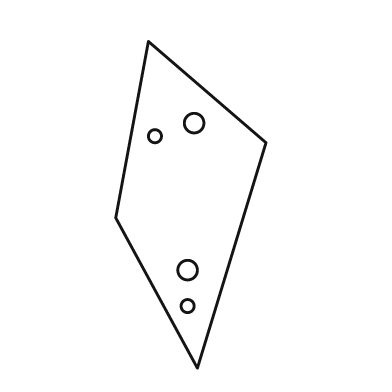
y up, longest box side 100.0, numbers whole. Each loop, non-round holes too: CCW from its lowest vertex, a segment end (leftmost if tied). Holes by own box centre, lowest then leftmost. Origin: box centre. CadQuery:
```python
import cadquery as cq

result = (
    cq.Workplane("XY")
    .moveTo(2.0, -50.0)
    .lineTo(23.0, 19.0)
    .lineTo(-13.0, 50.0)
    .lineTo(-23.0, -4.0)
    .close()
    .moveTo(-1.0, -31.0)
    .circle(2.0)
    .moveTo(-1.0, -20.0)
    .circle(3.0)
    .moveTo(-11.0, 21.0)
    .circle(2.0)
    .moveTo(1.0, 25.0)
    .circle(3.0)
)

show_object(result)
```